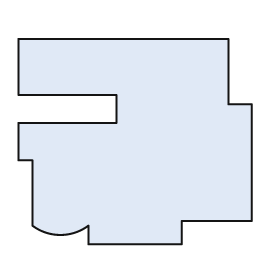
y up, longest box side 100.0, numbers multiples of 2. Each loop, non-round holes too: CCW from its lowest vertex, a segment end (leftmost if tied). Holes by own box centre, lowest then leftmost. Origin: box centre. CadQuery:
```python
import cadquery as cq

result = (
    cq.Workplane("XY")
    .moveTo(-20.0, -44.0)
    .lineTo(20.0, -44.0)
    .lineTo(20.0, -34.0)
    .lineTo(50.0, -34.0)
    .lineTo(50.0, 16.0)
    .lineTo(40.0, 16.0)
    .lineTo(40.0, 44.0)
    .lineTo(-50.0, 44.0)
    .lineTo(-50.0, 20.0)
    .lineTo(-8.0, 20.0)
    .lineTo(-8.0, 8.0)
    .lineTo(-50.0, 8.0)
    .lineTo(-50.0, -8.0)
    .lineTo(-44.0, -8.0)
    .lineTo(-44.0, -36.0)
    .threePointArc((-32.0, -40.0), (-20.0, -36.0))
    .close()
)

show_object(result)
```